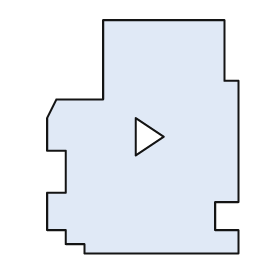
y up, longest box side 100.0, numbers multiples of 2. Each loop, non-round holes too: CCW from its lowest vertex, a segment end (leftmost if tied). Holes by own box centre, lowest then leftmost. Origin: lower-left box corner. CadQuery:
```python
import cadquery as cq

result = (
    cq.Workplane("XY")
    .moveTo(16.0, 0.0)
    .lineTo(82.0, 0.0)
    .lineTo(82.0, 10.0)
    .lineTo(72.0, 10.0)
    .lineTo(72.0, 22.0)
    .lineTo(82.0, 22.0)
    .lineTo(82.0, 74.0)
    .lineTo(76.0, 74.0)
    .lineTo(76.0, 100.0)
    .lineTo(24.0, 100.0)
    .lineTo(24.0, 66.0)
    .lineTo(4.0, 66.0)
    .lineTo(0.0, 58.0)
    .lineTo(0.0, 44.0)
    .lineTo(8.0, 44.0)
    .lineTo(8.0, 26.0)
    .lineTo(0.0, 26.0)
    .lineTo(0.0, 10.0)
    .lineTo(8.0, 10.0)
    .lineTo(8.0, 4.0)
    .lineTo(16.0, 4.0)
    .close()
    .moveTo(38.0, 42.0)
    .lineTo(50.0, 50.0)
    .lineTo(38.0, 58.0)
    .close()
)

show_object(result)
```